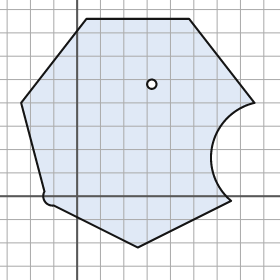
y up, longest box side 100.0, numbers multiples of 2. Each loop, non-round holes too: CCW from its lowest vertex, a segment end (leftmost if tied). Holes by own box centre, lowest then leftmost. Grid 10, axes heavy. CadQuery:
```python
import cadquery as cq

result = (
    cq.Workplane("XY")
    .moveTo(26.0, -22.0)
    .lineTo(66.0, -2.0)
    .threePointArc((58.0, 22.0), (76.0, 40.0))
    .lineTo(48.0, 76.0)
    .lineTo(4.0, 76.0)
    .lineTo(-24.0, 40.0)
    .lineTo(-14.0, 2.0)
    .threePointArc((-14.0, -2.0), (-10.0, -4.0))
    .close()
    .moveTo(32.0, 48.0)
    .circle(2.0)
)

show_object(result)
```